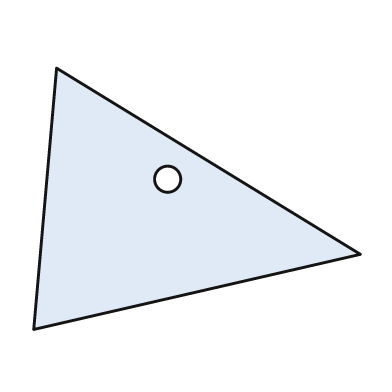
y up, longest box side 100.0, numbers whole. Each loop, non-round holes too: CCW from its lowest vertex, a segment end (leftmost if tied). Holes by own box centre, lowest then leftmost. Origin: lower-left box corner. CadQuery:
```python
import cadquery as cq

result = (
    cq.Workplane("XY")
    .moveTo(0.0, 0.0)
    .lineTo(100.0, 23.0)
    .lineTo(7.0, 80.0)
    .close()
    .moveTo(41.0, 46.0)
    .circle(4.0)
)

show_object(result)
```